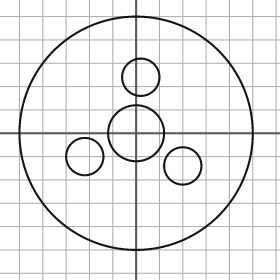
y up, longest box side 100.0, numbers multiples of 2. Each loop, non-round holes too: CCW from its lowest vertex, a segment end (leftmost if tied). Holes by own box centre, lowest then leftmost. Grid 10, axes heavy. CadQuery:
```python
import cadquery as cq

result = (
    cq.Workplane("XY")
    .moveTo(0.0, 0.0)
    .circle(50.0)
    .moveTo(20.0, -14.0)
    .circle(8.0)
    .moveTo(-22.0, -10.0)
    .circle(8.0)
    .moveTo(0.0, 0.0)
    .circle(12.0)
    .moveTo(2.0, 24.0)
    .circle(8.0)
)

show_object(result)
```